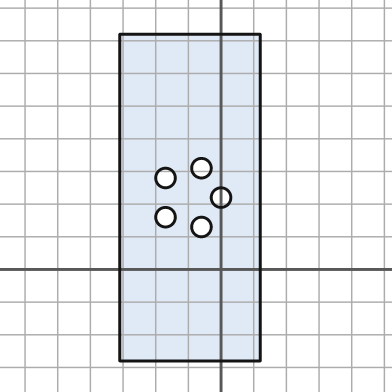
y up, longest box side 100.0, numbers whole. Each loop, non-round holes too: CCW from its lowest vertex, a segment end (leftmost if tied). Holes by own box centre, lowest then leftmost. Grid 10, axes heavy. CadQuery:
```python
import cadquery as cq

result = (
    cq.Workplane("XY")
    .moveTo(-31.0, -28.0)
    .lineTo(12.0, -28.0)
    .lineTo(12.0, 72.0)
    .lineTo(-31.0, 72.0)
    .close()
    .moveTo(-6.0, 13.0)
    .circle(3.0)
    .moveTo(-17.0, 16.0)
    .circle(3.0)
    .moveTo(0.0, 22.0)
    .circle(3.0)
    .moveTo(-17.0, 28.0)
    .circle(3.0)
    .moveTo(-6.0, 31.0)
    .circle(3.0)
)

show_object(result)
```